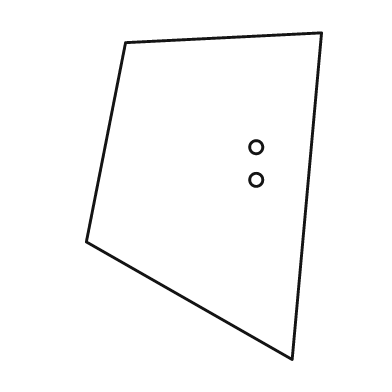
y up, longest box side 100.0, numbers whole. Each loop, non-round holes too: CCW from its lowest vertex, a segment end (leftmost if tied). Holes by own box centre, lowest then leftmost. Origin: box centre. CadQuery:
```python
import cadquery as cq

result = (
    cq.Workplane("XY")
    .moveTo(27.0, -50.0)
    .lineTo(36.0, 50.0)
    .lineTo(-24.0, 47.0)
    .lineTo(-36.0, -14.0)
    .close()
    .moveTo(16.0, 5.0)
    .circle(2.0)
    .moveTo(16.0, 15.0)
    .circle(2.0)
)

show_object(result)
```